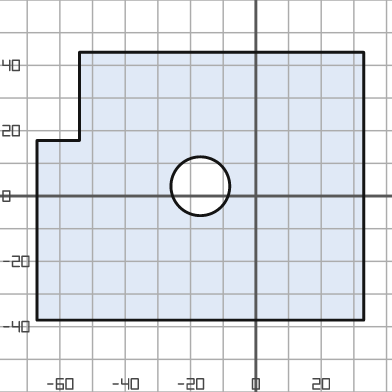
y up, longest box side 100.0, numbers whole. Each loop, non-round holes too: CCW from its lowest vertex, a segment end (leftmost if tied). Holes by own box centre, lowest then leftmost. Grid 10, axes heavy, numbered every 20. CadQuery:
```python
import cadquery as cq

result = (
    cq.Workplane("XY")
    .moveTo(-67.0, -38.0)
    .lineTo(33.0, -38.0)
    .lineTo(33.0, 44.0)
    .lineTo(-54.0, 44.0)
    .lineTo(-54.0, 17.0)
    .lineTo(-67.0, 17.0)
    .close()
    .moveTo(-17.0, 3.0)
    .circle(9.0)
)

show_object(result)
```